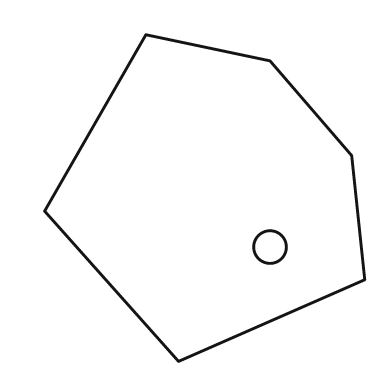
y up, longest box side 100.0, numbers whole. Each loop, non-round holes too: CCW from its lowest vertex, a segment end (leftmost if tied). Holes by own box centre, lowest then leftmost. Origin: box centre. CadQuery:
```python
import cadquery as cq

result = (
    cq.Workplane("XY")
    .moveTo(-8.0, -50.0)
    .lineTo(49.0, -25.0)
    .lineTo(45.0, 13.0)
    .lineTo(20.0, 42.0)
    .lineTo(-18.0, 50.0)
    .lineTo(-49.0, -4.0)
    .close()
    .moveTo(20.0, -15.0)
    .circle(5.0)
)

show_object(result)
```